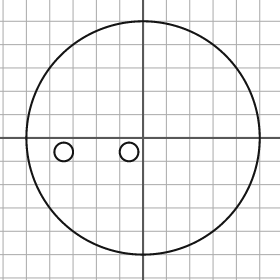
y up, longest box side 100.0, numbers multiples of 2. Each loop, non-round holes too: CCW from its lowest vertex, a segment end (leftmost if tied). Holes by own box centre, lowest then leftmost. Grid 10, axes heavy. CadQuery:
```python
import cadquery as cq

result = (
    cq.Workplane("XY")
    .moveTo(0.0, 0.0)
    .circle(50.0)
    .moveTo(-34.0, -6.0)
    .circle(4.0)
    .moveTo(-6.0, -6.0)
    .circle(4.0)
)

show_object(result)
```